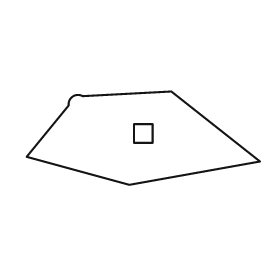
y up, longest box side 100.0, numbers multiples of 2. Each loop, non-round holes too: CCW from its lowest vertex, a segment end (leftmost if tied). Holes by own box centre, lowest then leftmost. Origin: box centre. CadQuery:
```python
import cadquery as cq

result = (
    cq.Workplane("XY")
    .moveTo(-6.0, -20.0)
    .lineTo(50.0, -10.0)
    .lineTo(12.0, 20.0)
    .lineTo(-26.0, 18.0)
    .threePointArc((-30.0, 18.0), (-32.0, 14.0))
    .lineTo(-50.0, -8.0)
    .close()
    .moveTo(-4.0, -2.0)
    .lineTo(4.0, -2.0)
    .lineTo(4.0, 6.0)
    .lineTo(-4.0, 6.0)
    .close()
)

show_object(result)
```